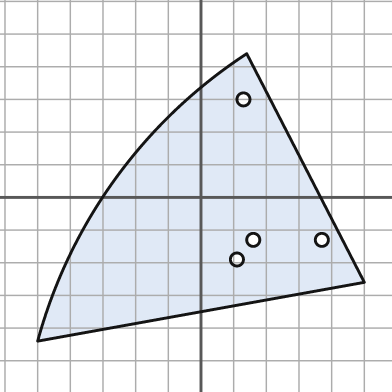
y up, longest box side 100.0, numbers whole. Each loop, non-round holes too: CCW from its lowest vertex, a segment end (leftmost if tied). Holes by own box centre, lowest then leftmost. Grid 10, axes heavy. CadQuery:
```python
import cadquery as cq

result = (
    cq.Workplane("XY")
    .moveTo(-50.0, -44.0)
    .lineTo(50.0, -26.0)
    .lineTo(14.0, 44.0)
    .threePointArc((-26.0, 6.0), (-50.0, -44.0))
    .close()
    .moveTo(11.0, -19.0)
    .circle(2.0)
    .moveTo(16.0, -13.0)
    .circle(2.0)
    .moveTo(37.0, -13.0)
    .circle(2.0)
    .moveTo(13.0, 30.0)
    .circle(2.0)
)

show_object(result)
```